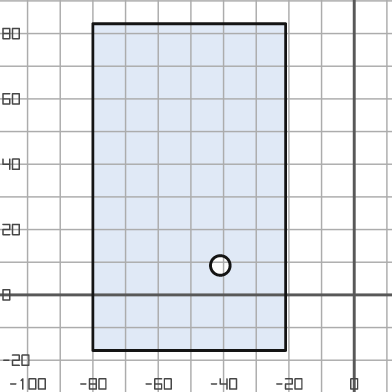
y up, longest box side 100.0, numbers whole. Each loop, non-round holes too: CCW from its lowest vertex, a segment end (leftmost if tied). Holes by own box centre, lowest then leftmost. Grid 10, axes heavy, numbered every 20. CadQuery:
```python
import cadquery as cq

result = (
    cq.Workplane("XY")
    .moveTo(-80.0, -17.0)
    .lineTo(-21.0, -17.0)
    .lineTo(-21.0, 83.0)
    .lineTo(-80.0, 83.0)
    .close()
    .moveTo(-41.0, 9.0)
    .circle(3.0)
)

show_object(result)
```